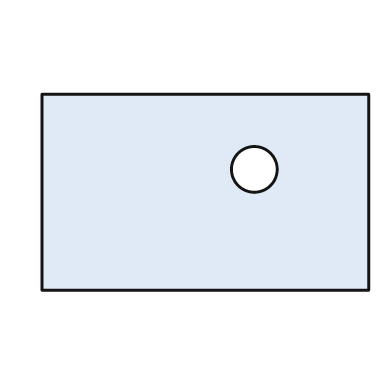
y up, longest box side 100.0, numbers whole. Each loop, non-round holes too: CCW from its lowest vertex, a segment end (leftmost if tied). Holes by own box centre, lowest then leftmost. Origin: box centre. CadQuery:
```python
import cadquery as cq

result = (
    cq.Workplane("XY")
    .moveTo(-50.0, -30.0)
    .lineTo(50.0, -30.0)
    .lineTo(50.0, 30.0)
    .lineTo(-50.0, 30.0)
    .close()
    .moveTo(15.0, 7.0)
    .circle(7.0)
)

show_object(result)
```